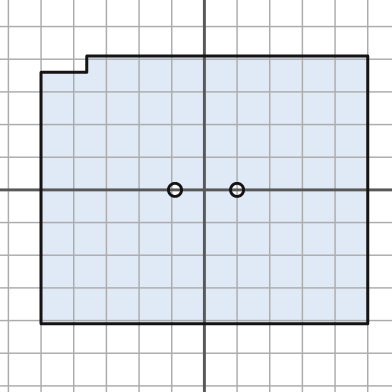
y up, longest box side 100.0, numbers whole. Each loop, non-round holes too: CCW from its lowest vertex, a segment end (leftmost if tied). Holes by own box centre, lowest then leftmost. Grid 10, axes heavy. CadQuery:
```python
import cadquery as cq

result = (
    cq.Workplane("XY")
    .moveTo(-50.0, -41.0)
    .lineTo(50.0, -41.0)
    .lineTo(50.0, 41.0)
    .lineTo(-36.0, 41.0)
    .lineTo(-36.0, 36.0)
    .lineTo(-50.0, 36.0)
    .close()
    .moveTo(-9.0, 0.0)
    .circle(2.0)
    .moveTo(10.0, 0.0)
    .circle(2.0)
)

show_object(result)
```